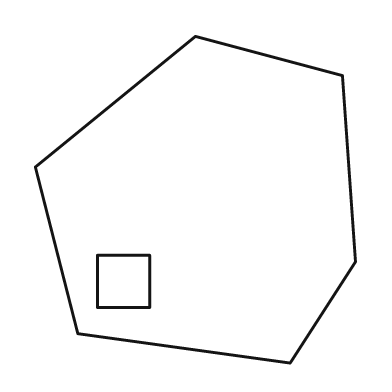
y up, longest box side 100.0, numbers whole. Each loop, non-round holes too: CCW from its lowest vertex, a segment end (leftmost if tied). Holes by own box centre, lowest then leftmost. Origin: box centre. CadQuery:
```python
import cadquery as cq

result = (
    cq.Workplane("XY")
    .moveTo(29.0, -50.0)
    .lineTo(49.0, -19.0)
    .lineTo(45.0, 38.0)
    .lineTo(0.0, 50.0)
    .lineTo(-49.0, 10.0)
    .lineTo(-36.0, -41.0)
    .close()
    .moveTo(-30.0, -33.0)
    .lineTo(-14.0, -33.0)
    .lineTo(-14.0, -17.0)
    .lineTo(-30.0, -17.0)
    .close()
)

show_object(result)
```